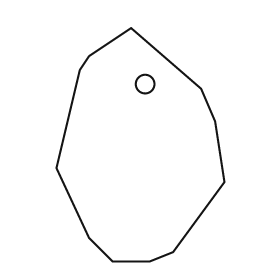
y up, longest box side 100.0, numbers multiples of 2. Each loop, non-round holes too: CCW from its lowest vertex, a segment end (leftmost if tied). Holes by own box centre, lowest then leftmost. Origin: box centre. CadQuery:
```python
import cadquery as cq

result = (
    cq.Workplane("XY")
    .moveTo(-12.0, -50.0)
    .lineTo(4.0, -50.0)
    .lineTo(14.0, -46.0)
    .lineTo(36.0, -16.0)
    .lineTo(32.0, 10.0)
    .lineTo(26.0, 24.0)
    .lineTo(-4.0, 50.0)
    .lineTo(-22.0, 38.0)
    .lineTo(-26.0, 32.0)
    .lineTo(-36.0, -10.0)
    .lineTo(-22.0, -40.0)
    .close()
    .moveTo(2.0, 26.0)
    .circle(4.0)
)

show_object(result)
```